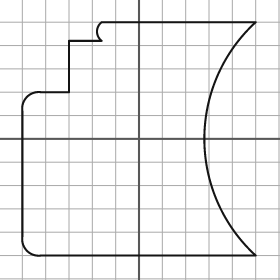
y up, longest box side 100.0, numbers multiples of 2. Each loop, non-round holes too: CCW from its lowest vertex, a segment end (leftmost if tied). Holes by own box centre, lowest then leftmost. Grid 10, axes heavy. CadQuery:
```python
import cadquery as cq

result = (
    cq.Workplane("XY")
    .moveTo(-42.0, -50.0)
    .lineTo(50.0, -50.0)
    .threePointArc((28.0, 0.0), (50.0, 50.0))
    .lineTo(-16.0, 50.0)
    .threePointArc((-18.0, 46.0), (-16.0, 42.0))
    .lineTo(-30.0, 42.0)
    .lineTo(-30.0, 20.0)
    .lineTo(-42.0, 20.0)
    .threePointArc((-48.0, 18.0), (-50.0, 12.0))
    .lineTo(-50.0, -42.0)
    .threePointArc((-48.0, -48.0), (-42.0, -50.0))
    .close()
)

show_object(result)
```